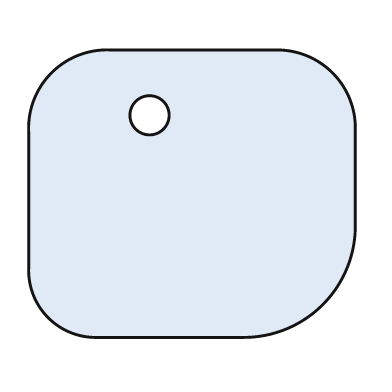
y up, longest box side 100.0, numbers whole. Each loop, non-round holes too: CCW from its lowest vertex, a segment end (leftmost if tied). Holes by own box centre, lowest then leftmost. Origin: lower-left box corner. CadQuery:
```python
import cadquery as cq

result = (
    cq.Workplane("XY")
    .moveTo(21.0, 0.0)
    .lineTo(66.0, 0.0)
    .threePointArc((90.0, 10.0), (100.0, 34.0))
    .lineTo(100.0, 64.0)
    .threePointArc((93.0, 81.0), (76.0, 88.0))
    .lineTo(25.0, 88.0)
    .threePointArc((7.0, 81.0), (0.0, 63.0))
    .lineTo(0.0, 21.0)
    .threePointArc((6.0, 6.0), (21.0, 0.0))
    .close()
    .moveTo(37.0, 68.0)
    .circle(6.0)
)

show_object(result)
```